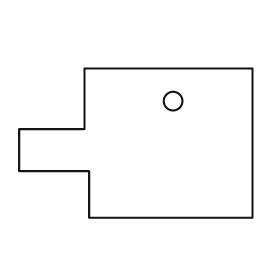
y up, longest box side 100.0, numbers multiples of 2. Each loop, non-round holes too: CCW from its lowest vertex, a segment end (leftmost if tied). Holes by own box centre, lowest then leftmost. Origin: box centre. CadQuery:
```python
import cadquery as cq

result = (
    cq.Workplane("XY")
    .moveTo(-20.0, -32.0)
    .lineTo(50.0, -32.0)
    .lineTo(50.0, 32.0)
    .lineTo(-22.0, 32.0)
    .lineTo(-22.0, 6.0)
    .lineTo(-50.0, 6.0)
    .lineTo(-50.0, -12.0)
    .lineTo(-20.0, -12.0)
    .close()
    .moveTo(16.0, 18.0)
    .circle(4.0)
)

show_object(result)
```